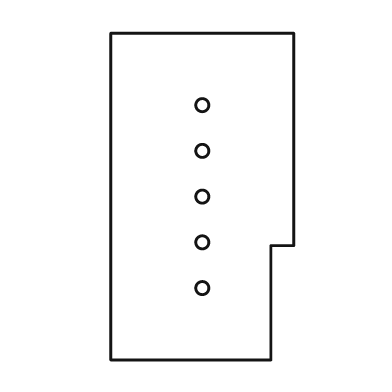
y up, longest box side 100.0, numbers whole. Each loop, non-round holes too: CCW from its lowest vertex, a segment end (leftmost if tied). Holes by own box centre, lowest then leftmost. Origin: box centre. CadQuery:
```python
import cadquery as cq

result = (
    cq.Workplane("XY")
    .moveTo(-28.0, -50.0)
    .lineTo(21.0, -50.0)
    .lineTo(21.0, -15.0)
    .lineTo(28.0, -15.0)
    .lineTo(28.0, 50.0)
    .lineTo(-28.0, 50.0)
    .close()
    .moveTo(0.0, -28.0)
    .circle(2.0)
    .moveTo(0.0, -14.0)
    .circle(2.0)
    .moveTo(0.0, 0.0)
    .circle(2.0)
    .moveTo(0.0, 14.0)
    .circle(2.0)
    .moveTo(0.0, 28.0)
    .circle(2.0)
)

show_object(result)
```